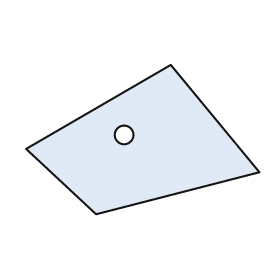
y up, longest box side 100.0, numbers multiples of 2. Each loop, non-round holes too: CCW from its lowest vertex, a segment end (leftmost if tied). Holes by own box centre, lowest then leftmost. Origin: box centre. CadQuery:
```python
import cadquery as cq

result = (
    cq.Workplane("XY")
    .moveTo(-20.0, -32.0)
    .lineTo(50.0, -14.0)
    .lineTo(12.0, 32.0)
    .lineTo(-50.0, -4.0)
    .close()
    .moveTo(-8.0, 2.0)
    .circle(4.0)
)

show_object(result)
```